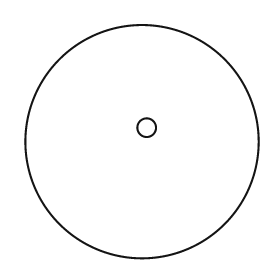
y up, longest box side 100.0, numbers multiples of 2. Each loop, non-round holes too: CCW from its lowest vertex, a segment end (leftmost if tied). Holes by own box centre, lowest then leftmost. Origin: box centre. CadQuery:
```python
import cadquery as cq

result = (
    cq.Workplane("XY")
    .moveTo(0.0, 0.0)
    .circle(50.0)
    .moveTo(2.0, 6.0)
    .circle(4.0)
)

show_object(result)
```